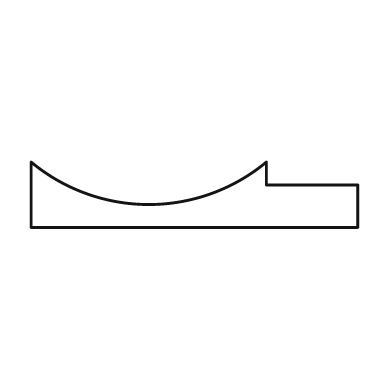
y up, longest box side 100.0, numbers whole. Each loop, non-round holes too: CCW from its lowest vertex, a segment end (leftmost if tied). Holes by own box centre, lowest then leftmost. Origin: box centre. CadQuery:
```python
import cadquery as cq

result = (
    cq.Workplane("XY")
    .moveTo(-50.0, -10.0)
    .lineTo(50.0, -10.0)
    .lineTo(50.0, 3.0)
    .lineTo(22.0, 3.0)
    .lineTo(22.0, 10.0)
    .threePointArc((-14.0, -3.0), (-50.0, 10.0))
    .close()
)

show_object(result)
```